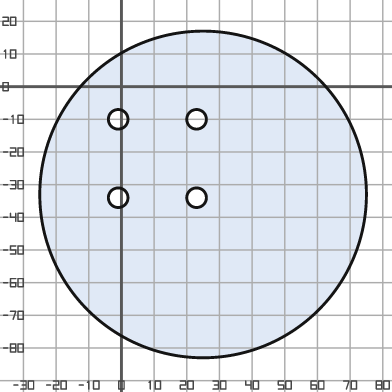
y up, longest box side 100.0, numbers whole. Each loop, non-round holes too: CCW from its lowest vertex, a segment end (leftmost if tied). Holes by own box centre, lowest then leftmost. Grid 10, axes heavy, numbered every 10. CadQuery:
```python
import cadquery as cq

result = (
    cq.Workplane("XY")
    .moveTo(25.0, -33.0)
    .circle(50.0)
    .moveTo(-1.0, -34.0)
    .circle(3.0)
    .moveTo(23.0, -34.0)
    .circle(3.0)
    .moveTo(-1.0, -10.0)
    .circle(3.0)
    .moveTo(23.0, -10.0)
    .circle(3.0)
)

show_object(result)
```